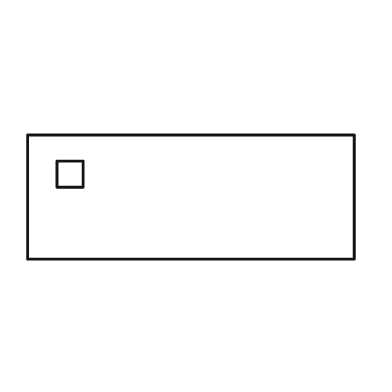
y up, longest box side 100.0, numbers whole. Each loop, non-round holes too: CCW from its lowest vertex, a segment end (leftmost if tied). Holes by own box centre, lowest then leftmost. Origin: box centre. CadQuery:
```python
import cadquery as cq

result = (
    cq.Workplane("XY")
    .moveTo(-50.0, -19.0)
    .lineTo(50.0, -19.0)
    .lineTo(50.0, 19.0)
    .lineTo(-50.0, 19.0)
    .close()
    .moveTo(-41.0, 3.0)
    .lineTo(-33.0, 3.0)
    .lineTo(-33.0, 11.0)
    .lineTo(-41.0, 11.0)
    .close()
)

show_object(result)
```